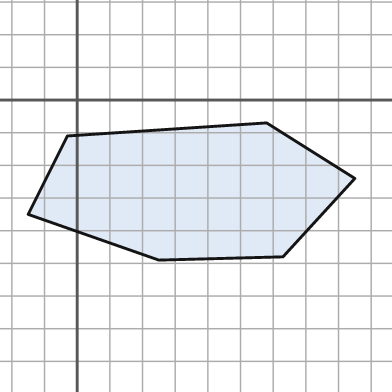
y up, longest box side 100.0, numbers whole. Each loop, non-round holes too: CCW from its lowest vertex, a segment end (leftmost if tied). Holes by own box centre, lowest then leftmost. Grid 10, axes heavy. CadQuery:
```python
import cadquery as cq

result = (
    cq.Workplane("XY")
    .moveTo(25.0, -49.0)
    .lineTo(63.0, -48.0)
    .lineTo(85.0, -24.0)
    .lineTo(58.0, -7.0)
    .lineTo(-3.0, -11.0)
    .lineTo(-15.0, -35.0)
    .close()
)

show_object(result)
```